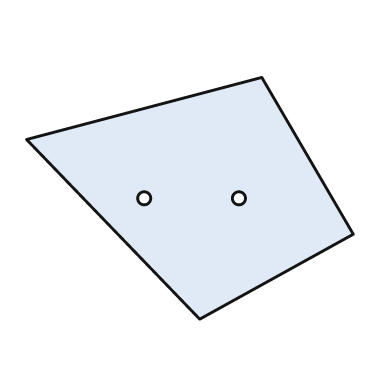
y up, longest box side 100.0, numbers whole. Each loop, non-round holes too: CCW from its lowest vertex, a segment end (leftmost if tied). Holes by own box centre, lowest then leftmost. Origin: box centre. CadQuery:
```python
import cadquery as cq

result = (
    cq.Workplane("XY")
    .moveTo(3.0, -37.0)
    .lineTo(50.0, -11.0)
    .lineTo(22.0, 37.0)
    .lineTo(-50.0, 18.0)
    .close()
    .moveTo(-14.0, 0.0)
    .circle(2.0)
    .moveTo(15.0, 0.0)
    .circle(2.0)
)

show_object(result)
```